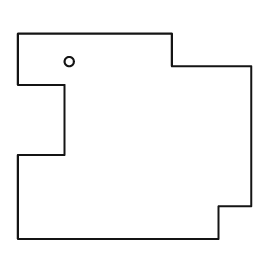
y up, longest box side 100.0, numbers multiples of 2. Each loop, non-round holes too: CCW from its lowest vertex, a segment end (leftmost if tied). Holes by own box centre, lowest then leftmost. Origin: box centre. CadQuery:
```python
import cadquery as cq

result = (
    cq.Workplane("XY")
    .moveTo(-50.0, -44.0)
    .lineTo(36.0, -44.0)
    .lineTo(36.0, -30.0)
    .lineTo(50.0, -30.0)
    .lineTo(50.0, 30.0)
    .lineTo(16.0, 30.0)
    .lineTo(16.0, 44.0)
    .lineTo(-50.0, 44.0)
    .lineTo(-50.0, 22.0)
    .lineTo(-30.0, 22.0)
    .lineTo(-30.0, -8.0)
    .lineTo(-50.0, -8.0)
    .close()
    .moveTo(-28.0, 32.0)
    .circle(2.0)
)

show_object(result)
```